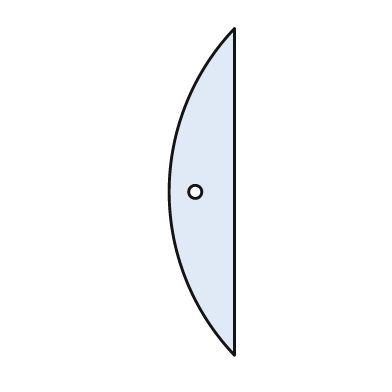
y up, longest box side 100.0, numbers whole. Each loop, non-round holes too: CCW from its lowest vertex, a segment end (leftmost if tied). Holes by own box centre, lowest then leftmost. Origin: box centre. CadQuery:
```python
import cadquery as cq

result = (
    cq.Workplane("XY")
    .moveTo(10.0, -50.0)
    .lineTo(10.0, 50.0)
    .threePointArc((-10.0, 0.0), (10.0, -50.0))
    .close()
    .moveTo(-2.0, 0.0)
    .circle(2.0)
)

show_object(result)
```